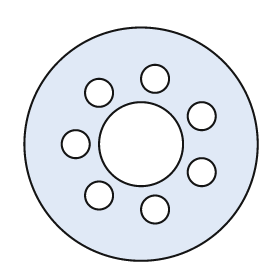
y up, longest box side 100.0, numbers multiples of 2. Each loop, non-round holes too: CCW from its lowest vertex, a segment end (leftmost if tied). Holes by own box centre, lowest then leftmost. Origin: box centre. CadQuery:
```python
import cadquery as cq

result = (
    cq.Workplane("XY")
    .moveTo(0.0, 0.0)
    .circle(50.0)
    .moveTo(6.0, -28.0)
    .circle(6.0)
    .moveTo(-18.0, -22.0)
    .circle(6.0)
    .moveTo(26.0, -12.0)
    .circle(6.0)
    .moveTo(-28.0, 0.0)
    .circle(6.0)
    .moveTo(0.0, 0.0)
    .circle(18.0)
    .moveTo(26.0, 12.0)
    .circle(6.0)
    .moveTo(-18.0, 22.0)
    .circle(6.0)
    .moveTo(6.0, 28.0)
    .circle(6.0)
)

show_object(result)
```